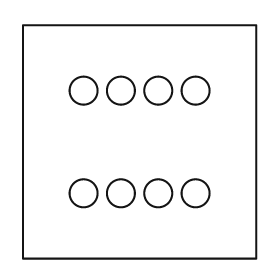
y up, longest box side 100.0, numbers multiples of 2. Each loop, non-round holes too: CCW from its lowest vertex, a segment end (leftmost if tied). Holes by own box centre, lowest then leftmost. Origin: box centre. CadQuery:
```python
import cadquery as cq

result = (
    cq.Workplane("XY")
    .moveTo(-50.0, -50.0)
    .lineTo(50.0, -50.0)
    .lineTo(50.0, 50.0)
    .lineTo(-50.0, 50.0)
    .close()
    .moveTo(-24.0, -22.0)
    .circle(6.0)
    .moveTo(-8.0, -22.0)
    .circle(6.0)
    .moveTo(8.0, -22.0)
    .circle(6.0)
    .moveTo(24.0, -22.0)
    .circle(6.0)
    .moveTo(-24.0, 22.0)
    .circle(6.0)
    .moveTo(-8.0, 22.0)
    .circle(6.0)
    .moveTo(8.0, 22.0)
    .circle(6.0)
    .moveTo(24.0, 22.0)
    .circle(6.0)
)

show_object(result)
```